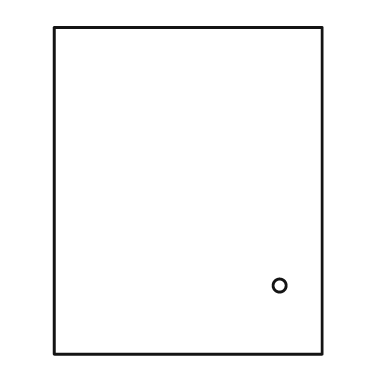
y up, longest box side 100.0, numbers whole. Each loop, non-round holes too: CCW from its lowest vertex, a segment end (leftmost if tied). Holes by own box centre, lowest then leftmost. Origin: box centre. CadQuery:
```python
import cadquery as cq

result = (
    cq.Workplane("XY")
    .moveTo(-41.0, -50.0)
    .lineTo(41.0, -50.0)
    .lineTo(41.0, 50.0)
    .lineTo(-41.0, 50.0)
    .close()
    .moveTo(28.0, -29.0)
    .circle(2.0)
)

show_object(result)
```